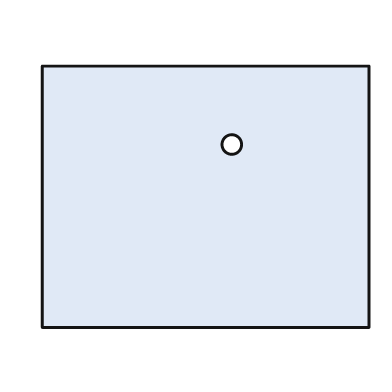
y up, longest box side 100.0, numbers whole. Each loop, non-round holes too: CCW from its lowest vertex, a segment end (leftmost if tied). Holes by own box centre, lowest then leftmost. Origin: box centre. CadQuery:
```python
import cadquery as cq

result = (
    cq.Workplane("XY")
    .moveTo(-50.0, -40.0)
    .lineTo(50.0, -40.0)
    .lineTo(50.0, 40.0)
    .lineTo(-50.0, 40.0)
    .close()
    .moveTo(8.0, 16.0)
    .circle(3.0)
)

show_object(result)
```